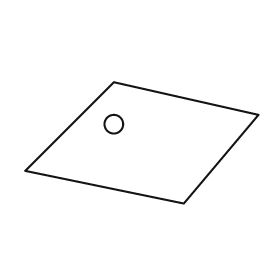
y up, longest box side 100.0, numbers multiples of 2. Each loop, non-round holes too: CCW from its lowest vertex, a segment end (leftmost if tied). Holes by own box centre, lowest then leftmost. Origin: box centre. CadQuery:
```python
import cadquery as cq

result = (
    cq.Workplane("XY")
    .moveTo(18.0, -26.0)
    .lineTo(50.0, 12.0)
    .lineTo(-12.0, 26.0)
    .lineTo(-50.0, -12.0)
    .close()
    .moveTo(-12.0, 8.0)
    .circle(4.0)
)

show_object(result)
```